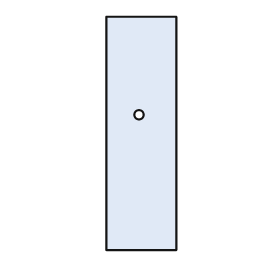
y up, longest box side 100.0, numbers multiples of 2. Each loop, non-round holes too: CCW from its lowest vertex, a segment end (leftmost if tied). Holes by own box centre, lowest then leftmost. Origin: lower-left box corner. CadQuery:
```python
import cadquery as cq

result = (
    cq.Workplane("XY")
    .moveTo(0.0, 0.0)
    .lineTo(30.0, 0.0)
    .lineTo(30.0, 100.0)
    .lineTo(0.0, 100.0)
    .close()
    .moveTo(14.0, 58.0)
    .circle(2.0)
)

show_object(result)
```